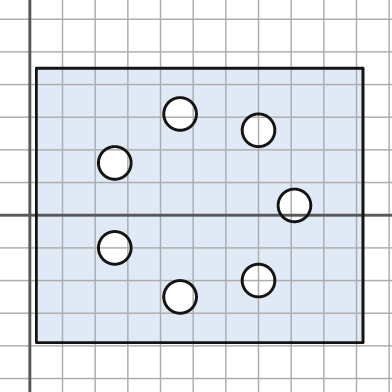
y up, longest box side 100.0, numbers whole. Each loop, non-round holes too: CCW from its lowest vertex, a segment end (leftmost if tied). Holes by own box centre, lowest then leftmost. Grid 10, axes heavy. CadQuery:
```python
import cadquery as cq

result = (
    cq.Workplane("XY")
    .moveTo(2.0, -39.0)
    .lineTo(102.0, -39.0)
    .lineTo(102.0, 45.0)
    .lineTo(2.0, 45.0)
    .close()
    .moveTo(46.0, -25.0)
    .circle(5.0)
    .moveTo(70.0, -20.0)
    .circle(5.0)
    .moveTo(26.0, -10.0)
    .circle(5.0)
    .moveTo(81.0, 3.0)
    .circle(5.0)
    .moveTo(26.0, 16.0)
    .circle(5.0)
    .moveTo(70.0, 26.0)
    .circle(5.0)
    .moveTo(46.0, 31.0)
    .circle(5.0)
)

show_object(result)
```